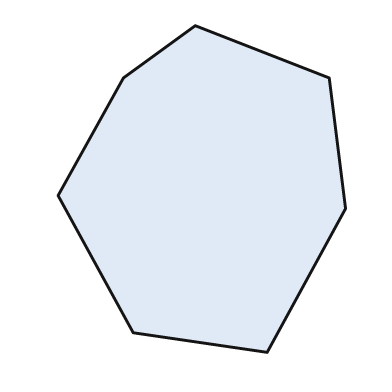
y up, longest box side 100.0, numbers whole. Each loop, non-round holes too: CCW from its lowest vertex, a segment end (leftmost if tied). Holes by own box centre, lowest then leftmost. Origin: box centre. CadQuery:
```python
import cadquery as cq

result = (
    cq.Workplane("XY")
    .moveTo(20.0, -50.0)
    .lineTo(44.0, -6.0)
    .lineTo(39.0, 34.0)
    .lineTo(-2.0, 50.0)
    .lineTo(-24.0, 34.0)
    .lineTo(-44.0, -2.0)
    .lineTo(-21.0, -44.0)
    .close()
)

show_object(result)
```